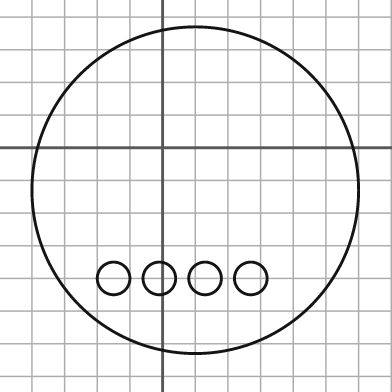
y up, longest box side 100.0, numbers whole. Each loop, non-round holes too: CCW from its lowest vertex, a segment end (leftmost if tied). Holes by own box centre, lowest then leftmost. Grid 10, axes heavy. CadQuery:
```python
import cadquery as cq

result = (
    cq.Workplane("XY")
    .moveTo(10.0, -13.0)
    .circle(50.0)
    .moveTo(-15.0, -40.0)
    .circle(5.0)
    .moveTo(-1.0, -40.0)
    .circle(5.0)
    .moveTo(13.0, -40.0)
    .circle(5.0)
    .moveTo(27.0, -40.0)
    .circle(5.0)
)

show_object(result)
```